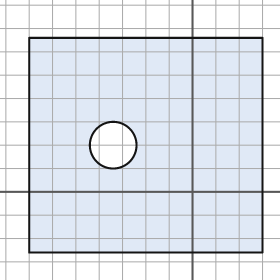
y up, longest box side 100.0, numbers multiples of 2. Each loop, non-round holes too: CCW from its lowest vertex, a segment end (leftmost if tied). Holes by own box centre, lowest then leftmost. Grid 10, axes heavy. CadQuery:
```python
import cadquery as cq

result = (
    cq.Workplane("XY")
    .moveTo(-70.0, -26.0)
    .lineTo(30.0, -26.0)
    .lineTo(30.0, 66.0)
    .lineTo(-70.0, 66.0)
    .close()
    .moveTo(-34.0, 20.0)
    .circle(10.0)
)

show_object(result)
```